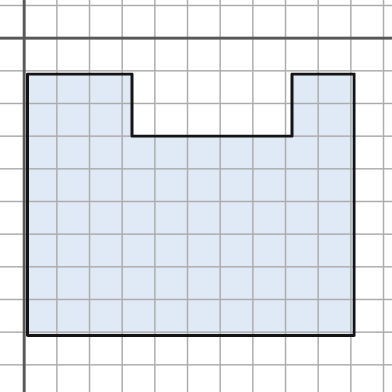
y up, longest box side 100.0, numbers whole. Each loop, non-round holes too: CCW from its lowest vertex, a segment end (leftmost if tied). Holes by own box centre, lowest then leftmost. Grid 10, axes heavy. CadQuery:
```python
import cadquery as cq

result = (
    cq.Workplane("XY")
    .moveTo(1.0, -91.0)
    .lineTo(101.0, -91.0)
    .lineTo(101.0, -11.0)
    .lineTo(82.0, -11.0)
    .lineTo(82.0, -30.0)
    .lineTo(33.0, -30.0)
    .lineTo(33.0, -11.0)
    .lineTo(1.0, -11.0)
    .close()
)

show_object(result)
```